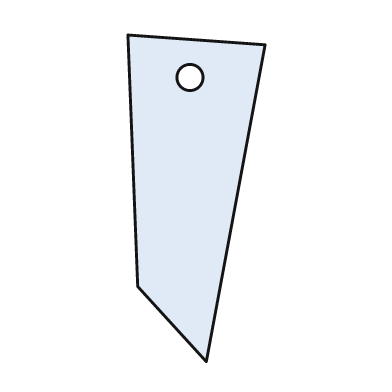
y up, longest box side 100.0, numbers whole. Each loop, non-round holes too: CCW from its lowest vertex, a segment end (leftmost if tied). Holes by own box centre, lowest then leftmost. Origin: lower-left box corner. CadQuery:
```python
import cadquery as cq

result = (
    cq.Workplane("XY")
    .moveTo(24.0, 0.0)
    .lineTo(42.0, 97.0)
    .lineTo(0.0, 100.0)
    .lineTo(3.0, 23.0)
    .close()
    .moveTo(19.0, 87.0)
    .circle(4.0)
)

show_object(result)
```